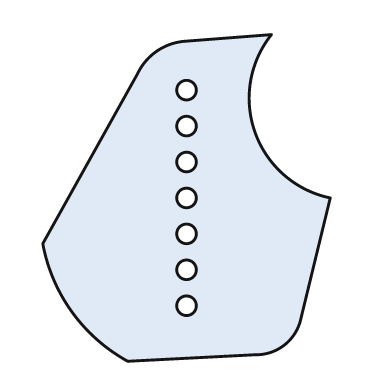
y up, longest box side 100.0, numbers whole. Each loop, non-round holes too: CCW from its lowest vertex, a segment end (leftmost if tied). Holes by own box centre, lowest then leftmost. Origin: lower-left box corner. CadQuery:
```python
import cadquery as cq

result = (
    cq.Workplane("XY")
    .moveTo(26.0, 0.0)
    .lineTo(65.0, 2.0)
    .threePointArc((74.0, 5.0), (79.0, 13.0))
    .lineTo(88.0, 50.0)
    .threePointArc((65.0, 70.0), (70.0, 100.0))
    .lineTo(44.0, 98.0)
    .threePointArc((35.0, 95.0), (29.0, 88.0))
    .lineTo(0.0, 36.0)
    .threePointArc((9.0, 15.0), (26.0, 0.0))
    .close()
    .moveTo(44.0, 17.0)
    .circle(3.0)
    .moveTo(44.0, 28.0)
    .circle(3.0)
    .moveTo(44.0, 39.0)
    .circle(3.0)
    .moveTo(44.0, 50.0)
    .circle(3.0)
    .moveTo(44.0, 61.0)
    .circle(3.0)
    .moveTo(44.0, 72.0)
    .circle(3.0)
    .moveTo(44.0, 83.0)
    .circle(3.0)
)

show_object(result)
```